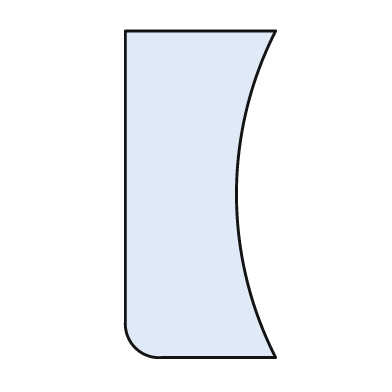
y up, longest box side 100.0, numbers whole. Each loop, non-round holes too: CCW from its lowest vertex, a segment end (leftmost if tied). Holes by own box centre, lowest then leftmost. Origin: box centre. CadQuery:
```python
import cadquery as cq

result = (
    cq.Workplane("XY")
    .moveTo(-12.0, -50.0)
    .lineTo(23.0, -50.0)
    .threePointArc((11.0, 0.0), (23.0, 50.0))
    .lineTo(-23.0, 50.0)
    .lineTo(-23.0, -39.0)
    .threePointArc((-20.0, -47.0), (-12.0, -50.0))
    .close()
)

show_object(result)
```